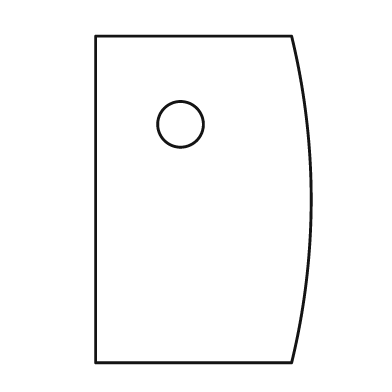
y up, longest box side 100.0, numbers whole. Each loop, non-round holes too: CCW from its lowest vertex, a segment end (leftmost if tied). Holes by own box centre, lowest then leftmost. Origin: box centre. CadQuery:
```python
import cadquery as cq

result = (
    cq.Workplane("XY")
    .moveTo(-33.0, -50.0)
    .lineTo(27.0, -50.0)
    .threePointArc((33.0, 0.0), (27.0, 50.0))
    .lineTo(-33.0, 50.0)
    .close()
    .moveTo(-7.0, 23.0)
    .circle(7.0)
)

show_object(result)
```